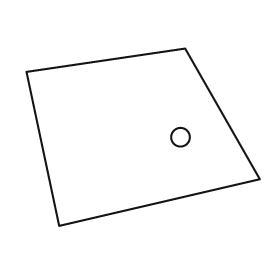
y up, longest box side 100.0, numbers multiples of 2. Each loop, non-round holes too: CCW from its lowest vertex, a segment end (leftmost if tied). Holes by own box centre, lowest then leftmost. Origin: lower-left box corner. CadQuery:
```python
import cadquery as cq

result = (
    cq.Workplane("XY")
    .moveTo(14.0, 0.0)
    .lineTo(100.0, 20.0)
    .lineTo(68.0, 76.0)
    .lineTo(0.0, 66.0)
    .close()
    .moveTo(66.0, 38.0)
    .circle(4.0)
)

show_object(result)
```